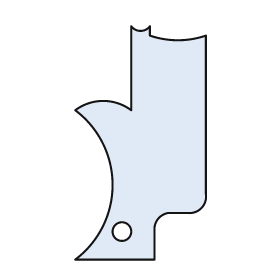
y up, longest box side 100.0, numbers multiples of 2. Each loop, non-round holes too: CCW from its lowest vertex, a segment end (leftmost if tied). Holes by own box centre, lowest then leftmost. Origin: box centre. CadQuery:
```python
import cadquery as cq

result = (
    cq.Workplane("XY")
    .moveTo(-28.0, -50.0)
    .lineTo(6.0, -50.0)
    .lineTo(6.0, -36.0)
    .threePointArc((8.0, -32.0), (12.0, -30.0))
    .lineTo(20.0, -30.0)
    .threePointArc((26.0, -28.0), (28.0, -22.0))
    .lineTo(28.0, 46.0)
    .threePointArc((16.0, 44.0), (4.0, 46.0))
    .lineTo(4.0, 50.0)
    .threePointArc((0.0, 48.0), (-4.0, 50.0))
    .lineTo(-4.0, 14.0)
    .threePointArc((-16.0, 18.0), (-28.0, 14.0))
    .threePointArc((-12.0, -18.0), (-28.0, -50.0))
    .close()
    .moveTo(-8.0, -38.0)
    .circle(4.0)
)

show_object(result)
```